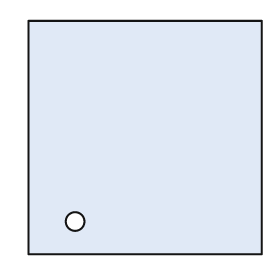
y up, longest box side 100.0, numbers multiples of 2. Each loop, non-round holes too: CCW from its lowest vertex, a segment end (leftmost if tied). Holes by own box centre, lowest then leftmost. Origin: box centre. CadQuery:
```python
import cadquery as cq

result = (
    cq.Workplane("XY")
    .moveTo(-50.0, -50.0)
    .lineTo(50.0, -50.0)
    .lineTo(50.0, 50.0)
    .lineTo(-50.0, 50.0)
    .close()
    .moveTo(-30.0, -36.0)
    .circle(4.0)
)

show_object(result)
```